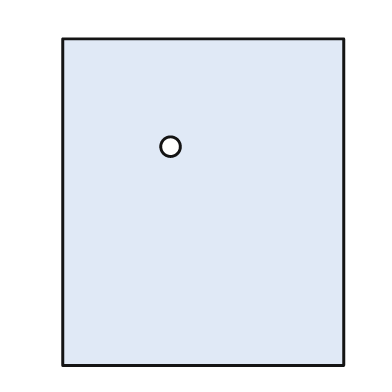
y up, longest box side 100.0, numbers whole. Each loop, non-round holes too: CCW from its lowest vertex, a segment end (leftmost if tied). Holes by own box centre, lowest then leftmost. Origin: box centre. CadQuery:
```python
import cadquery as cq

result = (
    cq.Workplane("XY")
    .moveTo(-43.0, -50.0)
    .lineTo(43.0, -50.0)
    .lineTo(43.0, 50.0)
    .lineTo(-43.0, 50.0)
    .close()
    .moveTo(-10.0, 17.0)
    .circle(3.0)
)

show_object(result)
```